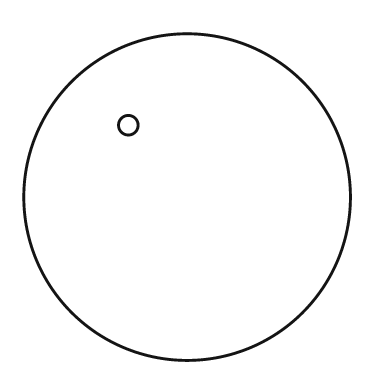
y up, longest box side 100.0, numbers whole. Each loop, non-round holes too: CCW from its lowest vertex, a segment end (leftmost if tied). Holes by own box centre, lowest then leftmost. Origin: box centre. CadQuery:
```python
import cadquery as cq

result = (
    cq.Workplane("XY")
    .moveTo(0.0, 0.0)
    .circle(50.0)
    .moveTo(-18.0, 22.0)
    .circle(3.0)
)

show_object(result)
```